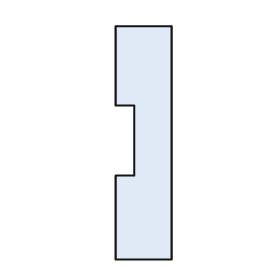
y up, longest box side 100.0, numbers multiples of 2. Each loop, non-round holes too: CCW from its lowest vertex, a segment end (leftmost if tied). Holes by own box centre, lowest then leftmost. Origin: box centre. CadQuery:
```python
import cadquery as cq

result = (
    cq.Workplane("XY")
    .moveTo(-12.0, -50.0)
    .lineTo(12.0, -50.0)
    .lineTo(12.0, 50.0)
    .lineTo(-12.0, 50.0)
    .lineTo(-12.0, 16.0)
    .lineTo(-4.0, 16.0)
    .lineTo(-4.0, -14.0)
    .lineTo(-12.0, -14.0)
    .close()
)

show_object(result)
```